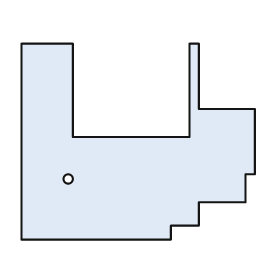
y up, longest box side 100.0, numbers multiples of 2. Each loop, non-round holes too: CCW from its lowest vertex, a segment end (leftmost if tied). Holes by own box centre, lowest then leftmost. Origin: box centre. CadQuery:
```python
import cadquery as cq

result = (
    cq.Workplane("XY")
    .moveTo(-50.0, -42.0)
    .lineTo(14.0, -42.0)
    .lineTo(14.0, -36.0)
    .lineTo(26.0, -36.0)
    .lineTo(26.0, -26.0)
    .lineTo(46.0, -26.0)
    .lineTo(46.0, -14.0)
    .lineTo(50.0, -14.0)
    .lineTo(50.0, 14.0)
    .lineTo(26.0, 14.0)
    .lineTo(26.0, 42.0)
    .lineTo(22.0, 42.0)
    .lineTo(22.0, 2.0)
    .lineTo(-28.0, 2.0)
    .lineTo(-28.0, 42.0)
    .lineTo(-50.0, 42.0)
    .close()
    .moveTo(-30.0, -16.0)
    .circle(2.0)
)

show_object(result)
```